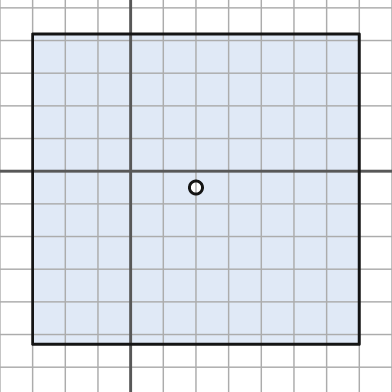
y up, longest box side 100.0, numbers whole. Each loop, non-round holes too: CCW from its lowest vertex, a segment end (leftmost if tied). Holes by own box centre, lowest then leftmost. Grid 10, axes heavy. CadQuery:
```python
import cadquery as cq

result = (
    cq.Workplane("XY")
    .moveTo(-30.0, -53.0)
    .lineTo(70.0, -53.0)
    .lineTo(70.0, 42.0)
    .lineTo(-30.0, 42.0)
    .close()
    .moveTo(20.0, -5.0)
    .circle(2.0)
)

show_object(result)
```